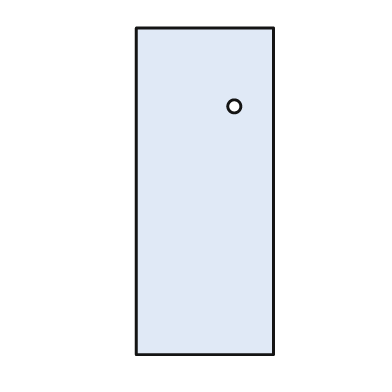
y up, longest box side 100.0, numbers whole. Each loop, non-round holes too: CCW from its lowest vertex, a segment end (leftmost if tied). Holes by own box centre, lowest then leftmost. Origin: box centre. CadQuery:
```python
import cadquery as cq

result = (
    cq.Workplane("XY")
    .moveTo(-21.0, -50.0)
    .lineTo(21.0, -50.0)
    .lineTo(21.0, 50.0)
    .lineTo(-21.0, 50.0)
    .close()
    .moveTo(9.0, 26.0)
    .circle(2.0)
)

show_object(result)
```